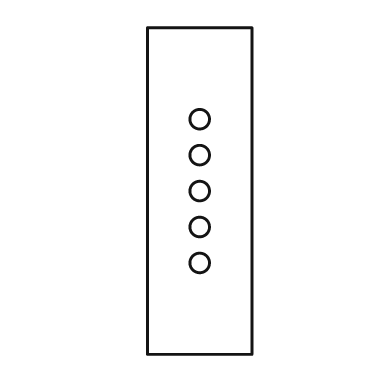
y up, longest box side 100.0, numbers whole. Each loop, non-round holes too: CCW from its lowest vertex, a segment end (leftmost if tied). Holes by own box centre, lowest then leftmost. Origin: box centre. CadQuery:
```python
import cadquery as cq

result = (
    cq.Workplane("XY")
    .moveTo(-16.0, -50.0)
    .lineTo(16.0, -50.0)
    .lineTo(16.0, 50.0)
    .lineTo(-16.0, 50.0)
    .close()
    .moveTo(0.0, -22.0)
    .circle(3.0)
    .moveTo(0.0, -11.0)
    .circle(3.0)
    .moveTo(0.0, 0.0)
    .circle(3.0)
    .moveTo(0.0, 11.0)
    .circle(3.0)
    .moveTo(0.0, 22.0)
    .circle(3.0)
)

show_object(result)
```